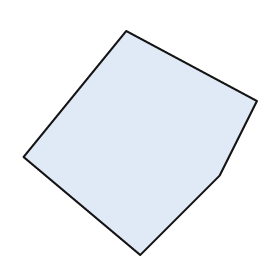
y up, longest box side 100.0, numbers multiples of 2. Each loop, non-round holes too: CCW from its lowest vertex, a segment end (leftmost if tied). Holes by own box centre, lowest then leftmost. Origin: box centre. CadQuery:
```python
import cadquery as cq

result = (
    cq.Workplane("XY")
    .moveTo(0.0, -48.0)
    .lineTo(34.0, -14.0)
    .lineTo(50.0, 18.0)
    .lineTo(-6.0, 48.0)
    .lineTo(-50.0, -6.0)
    .close()
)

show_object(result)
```